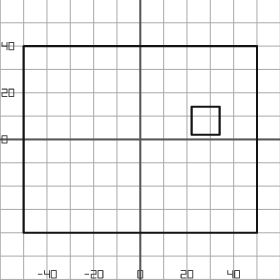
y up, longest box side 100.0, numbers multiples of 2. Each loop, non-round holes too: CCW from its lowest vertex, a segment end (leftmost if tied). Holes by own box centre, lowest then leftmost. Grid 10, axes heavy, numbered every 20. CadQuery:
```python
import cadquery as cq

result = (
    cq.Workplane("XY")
    .moveTo(-50.0, -40.0)
    .lineTo(50.0, -40.0)
    .lineTo(50.0, 40.0)
    .lineTo(-50.0, 40.0)
    .close()
    .moveTo(22.0, 2.0)
    .lineTo(34.0, 2.0)
    .lineTo(34.0, 14.0)
    .lineTo(22.0, 14.0)
    .close()
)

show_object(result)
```